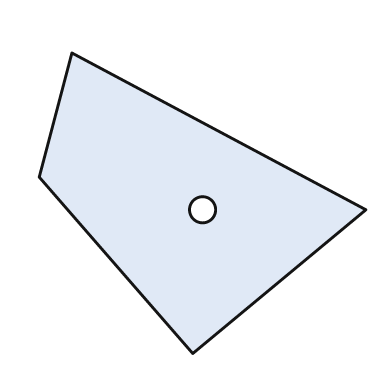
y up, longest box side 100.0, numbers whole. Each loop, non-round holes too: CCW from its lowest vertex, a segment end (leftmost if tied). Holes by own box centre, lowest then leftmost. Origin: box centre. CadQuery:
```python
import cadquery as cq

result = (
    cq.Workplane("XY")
    .moveTo(-3.0, -46.0)
    .lineTo(50.0, -2.0)
    .lineTo(-40.0, 46.0)
    .lineTo(-50.0, 8.0)
    .close()
    .moveTo(0.0, -2.0)
    .circle(4.0)
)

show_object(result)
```